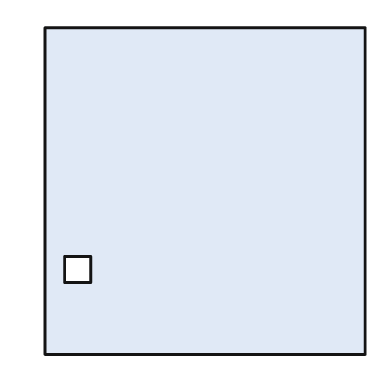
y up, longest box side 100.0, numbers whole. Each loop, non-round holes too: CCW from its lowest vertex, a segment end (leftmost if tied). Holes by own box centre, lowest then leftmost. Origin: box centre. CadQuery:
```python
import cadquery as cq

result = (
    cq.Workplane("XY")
    .moveTo(-49.0, -50.0)
    .lineTo(49.0, -50.0)
    .lineTo(49.0, 50.0)
    .lineTo(-49.0, 50.0)
    .close()
    .moveTo(-43.0, -28.0)
    .lineTo(-35.0, -28.0)
    .lineTo(-35.0, -20.0)
    .lineTo(-43.0, -20.0)
    .close()
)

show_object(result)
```